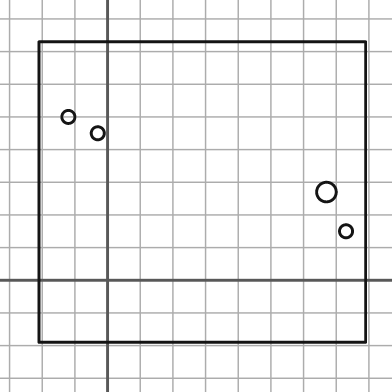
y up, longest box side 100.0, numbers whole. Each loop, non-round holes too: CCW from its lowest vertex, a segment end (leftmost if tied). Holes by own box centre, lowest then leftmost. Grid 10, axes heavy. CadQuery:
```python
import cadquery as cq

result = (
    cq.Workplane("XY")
    .moveTo(-21.0, -19.0)
    .lineTo(79.0, -19.0)
    .lineTo(79.0, 73.0)
    .lineTo(-21.0, 73.0)
    .close()
    .moveTo(73.0, 15.0)
    .circle(2.0)
    .moveTo(67.0, 27.0)
    .circle(3.0)
    .moveTo(-3.0, 45.0)
    .circle(2.0)
    .moveTo(-12.0, 50.0)
    .circle(2.0)
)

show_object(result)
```